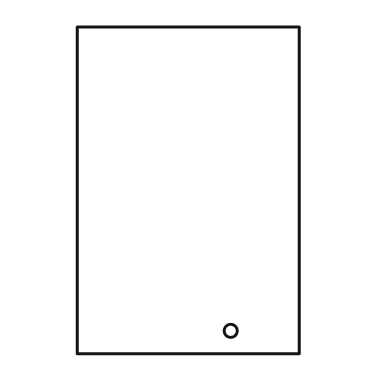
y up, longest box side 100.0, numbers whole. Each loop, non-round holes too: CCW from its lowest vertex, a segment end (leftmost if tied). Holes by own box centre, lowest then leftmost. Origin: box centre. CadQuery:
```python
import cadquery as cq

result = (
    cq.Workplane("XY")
    .moveTo(-34.0, -50.0)
    .lineTo(34.0, -50.0)
    .lineTo(34.0, 50.0)
    .lineTo(-34.0, 50.0)
    .close()
    .moveTo(13.0, -43.0)
    .circle(2.0)
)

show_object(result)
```